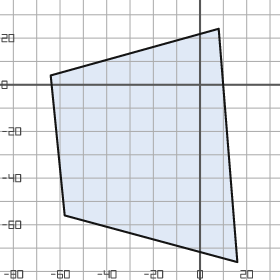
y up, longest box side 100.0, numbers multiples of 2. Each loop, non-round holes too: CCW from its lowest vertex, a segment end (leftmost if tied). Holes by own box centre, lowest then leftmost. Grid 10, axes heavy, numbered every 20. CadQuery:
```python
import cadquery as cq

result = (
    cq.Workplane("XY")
    .moveTo(16.0, -76.0)
    .lineTo(8.0, 24.0)
    .lineTo(-64.0, 4.0)
    .lineTo(-58.0, -56.0)
    .close()
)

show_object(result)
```